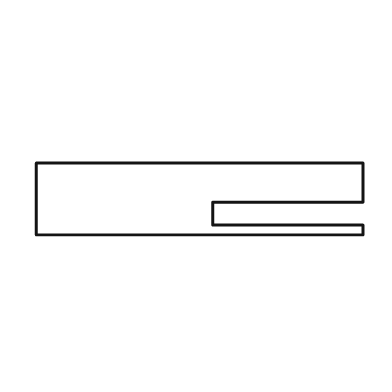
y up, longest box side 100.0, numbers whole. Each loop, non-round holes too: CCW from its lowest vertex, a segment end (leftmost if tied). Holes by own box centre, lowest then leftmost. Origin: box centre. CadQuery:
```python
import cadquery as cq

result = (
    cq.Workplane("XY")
    .moveTo(-50.0, -11.0)
    .lineTo(50.0, -11.0)
    .lineTo(50.0, -8.0)
    .lineTo(4.0, -8.0)
    .lineTo(4.0, -1.0)
    .lineTo(50.0, -1.0)
    .lineTo(50.0, 11.0)
    .lineTo(-50.0, 11.0)
    .close()
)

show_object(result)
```